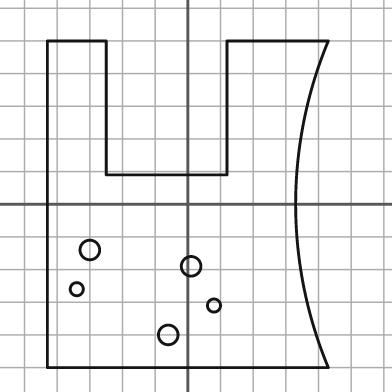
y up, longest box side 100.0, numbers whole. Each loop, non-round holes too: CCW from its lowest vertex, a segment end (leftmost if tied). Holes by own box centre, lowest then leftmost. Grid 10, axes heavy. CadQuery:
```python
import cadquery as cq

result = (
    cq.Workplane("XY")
    .moveTo(-43.0, -50.0)
    .lineTo(43.0, -50.0)
    .threePointArc((33.0, 0.0), (43.0, 50.0))
    .lineTo(12.0, 50.0)
    .lineTo(12.0, 9.0)
    .lineTo(-25.0, 9.0)
    .lineTo(-25.0, 50.0)
    .lineTo(-43.0, 50.0)
    .close()
    .moveTo(-6.0, -40.0)
    .circle(3.0)
    .moveTo(8.0, -31.0)
    .circle(2.0)
    .moveTo(-34.0, -26.0)
    .circle(2.0)
    .moveTo(1.0, -19.0)
    .circle(3.0)
    .moveTo(-30.0, -14.0)
    .circle(3.0)
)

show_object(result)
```